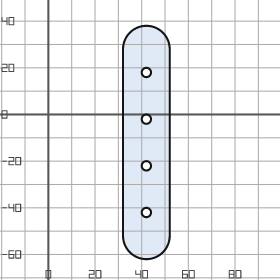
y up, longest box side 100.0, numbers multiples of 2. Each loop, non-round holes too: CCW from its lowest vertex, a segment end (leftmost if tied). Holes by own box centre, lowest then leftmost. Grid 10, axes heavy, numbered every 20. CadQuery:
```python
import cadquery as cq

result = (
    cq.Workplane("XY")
    .moveTo(32.0, -52.0)
    .threePointArc((42.0, -62.0), (52.0, -52.0))
    .lineTo(52.0, 28.0)
    .threePointArc((42.0, 38.0), (32.0, 28.0))
    .close()
    .moveTo(42.0, -42.0)
    .circle(2.0)
    .moveTo(42.0, -22.0)
    .circle(2.0)
    .moveTo(42.0, -2.0)
    .circle(2.0)
    .moveTo(42.0, 18.0)
    .circle(2.0)
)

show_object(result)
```